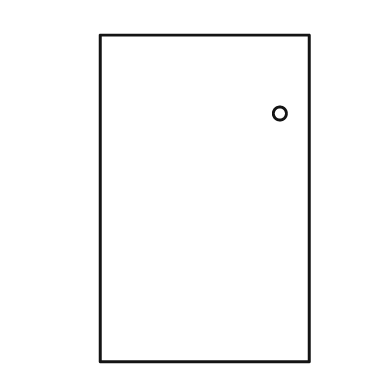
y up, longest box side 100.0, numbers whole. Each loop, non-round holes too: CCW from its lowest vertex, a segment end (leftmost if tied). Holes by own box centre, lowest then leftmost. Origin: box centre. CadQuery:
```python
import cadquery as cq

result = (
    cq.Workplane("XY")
    .moveTo(-32.0, -50.0)
    .lineTo(32.0, -50.0)
    .lineTo(32.0, 50.0)
    .lineTo(-32.0, 50.0)
    .close()
    .moveTo(23.0, 26.0)
    .circle(2.0)
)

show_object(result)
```